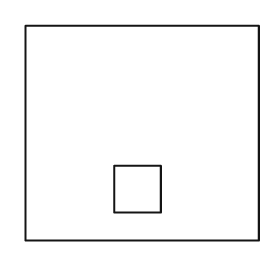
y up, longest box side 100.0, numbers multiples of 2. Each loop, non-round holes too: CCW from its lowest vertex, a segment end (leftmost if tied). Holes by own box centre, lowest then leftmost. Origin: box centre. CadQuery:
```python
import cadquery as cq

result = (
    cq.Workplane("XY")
    .moveTo(-50.0, -46.0)
    .lineTo(50.0, -46.0)
    .lineTo(50.0, 46.0)
    .lineTo(-50.0, 46.0)
    .close()
    .moveTo(-12.0, -34.0)
    .lineTo(8.0, -34.0)
    .lineTo(8.0, -14.0)
    .lineTo(-12.0, -14.0)
    .close()
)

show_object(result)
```